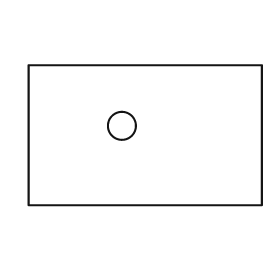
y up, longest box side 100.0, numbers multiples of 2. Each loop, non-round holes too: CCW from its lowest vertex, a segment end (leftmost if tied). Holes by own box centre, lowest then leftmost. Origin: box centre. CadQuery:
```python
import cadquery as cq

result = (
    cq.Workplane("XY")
    .moveTo(-50.0, -30.0)
    .lineTo(50.0, -30.0)
    .lineTo(50.0, 30.0)
    .lineTo(-50.0, 30.0)
    .close()
    .moveTo(-10.0, 4.0)
    .circle(6.0)
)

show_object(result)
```